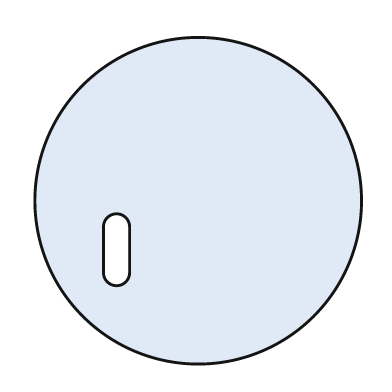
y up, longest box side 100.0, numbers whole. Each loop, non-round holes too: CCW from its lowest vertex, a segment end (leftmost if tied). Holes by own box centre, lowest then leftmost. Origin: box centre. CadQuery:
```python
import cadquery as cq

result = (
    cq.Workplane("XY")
    .moveTo(0.0, 0.0)
    .circle(50.0)
    .moveTo(-29.0, -22.0)
    .threePointArc((-25.0, -26.0), (-21.0, -22.0))
    .lineTo(-21.0, -8.0)
    .threePointArc((-25.0, -4.0), (-29.0, -8.0))
    .close()
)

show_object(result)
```